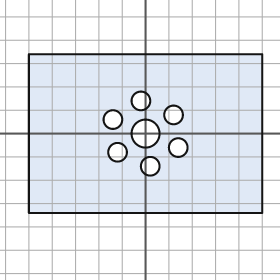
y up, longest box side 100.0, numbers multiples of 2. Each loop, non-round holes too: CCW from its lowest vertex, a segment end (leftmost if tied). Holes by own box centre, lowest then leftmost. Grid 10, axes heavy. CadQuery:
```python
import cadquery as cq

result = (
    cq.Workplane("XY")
    .moveTo(-50.0, -34.0)
    .lineTo(50.0, -34.0)
    .lineTo(50.0, 34.0)
    .lineTo(-50.0, 34.0)
    .close()
    .moveTo(2.0, -14.0)
    .circle(4.0)
    .moveTo(-12.0, -8.0)
    .circle(4.0)
    .moveTo(14.0, -6.0)
    .circle(4.0)
    .moveTo(0.0, 0.0)
    .circle(6.0)
    .moveTo(-14.0, 6.0)
    .circle(4.0)
    .moveTo(12.0, 8.0)
    .circle(4.0)
    .moveTo(-2.0, 14.0)
    .circle(4.0)
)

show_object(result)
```